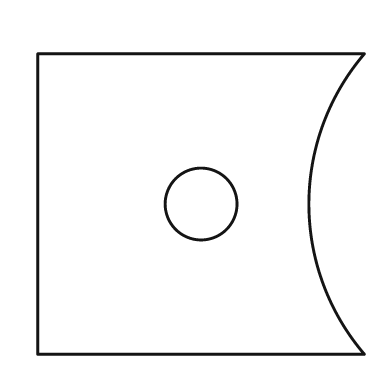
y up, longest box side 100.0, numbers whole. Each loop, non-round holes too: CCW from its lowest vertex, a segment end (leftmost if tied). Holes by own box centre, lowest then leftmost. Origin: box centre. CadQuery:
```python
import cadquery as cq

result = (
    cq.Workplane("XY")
    .moveTo(-50.0, -46.0)
    .lineTo(50.0, -46.0)
    .threePointArc((33.0, 0.0), (50.0, 46.0))
    .lineTo(-50.0, 46.0)
    .close()
    .moveTo(0.0, 0.0)
    .circle(11.0)
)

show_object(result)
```